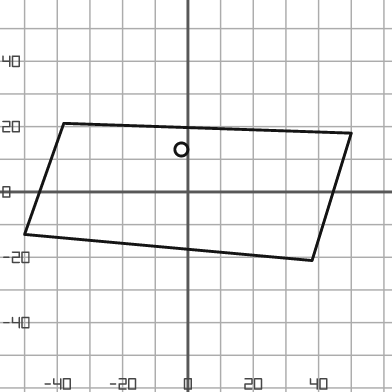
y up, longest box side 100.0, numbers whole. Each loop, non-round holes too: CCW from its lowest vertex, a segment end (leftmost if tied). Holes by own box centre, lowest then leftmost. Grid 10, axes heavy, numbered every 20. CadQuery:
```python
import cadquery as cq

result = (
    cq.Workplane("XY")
    .moveTo(38.0, -21.0)
    .lineTo(50.0, 18.0)
    .lineTo(-38.0, 21.0)
    .lineTo(-50.0, -13.0)
    .close()
    .moveTo(-2.0, 13.0)
    .circle(2.0)
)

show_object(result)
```